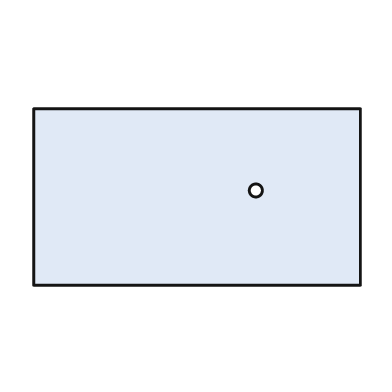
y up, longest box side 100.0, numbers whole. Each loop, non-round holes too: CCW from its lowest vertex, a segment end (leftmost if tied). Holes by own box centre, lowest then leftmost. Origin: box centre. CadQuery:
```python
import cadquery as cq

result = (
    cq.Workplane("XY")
    .moveTo(-50.0, -27.0)
    .lineTo(50.0, -27.0)
    .lineTo(50.0, 27.0)
    .lineTo(-50.0, 27.0)
    .close()
    .moveTo(18.0, 2.0)
    .circle(2.0)
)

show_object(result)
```